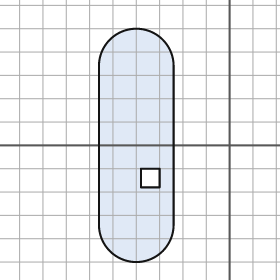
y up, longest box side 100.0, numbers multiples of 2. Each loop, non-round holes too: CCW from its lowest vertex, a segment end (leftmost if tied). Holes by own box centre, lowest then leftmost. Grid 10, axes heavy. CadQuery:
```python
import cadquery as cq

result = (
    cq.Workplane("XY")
    .moveTo(-56.0, -34.0)
    .threePointArc((-40.0, -50.0), (-24.0, -34.0))
    .lineTo(-24.0, 34.0)
    .threePointArc((-40.0, 50.0), (-56.0, 34.0))
    .close()
    .moveTo(-38.0, -18.0)
    .lineTo(-30.0, -18.0)
    .lineTo(-30.0, -10.0)
    .lineTo(-38.0, -10.0)
    .close()
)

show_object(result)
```